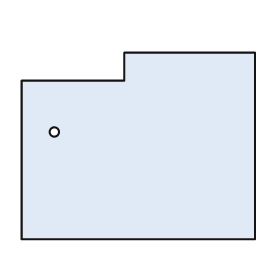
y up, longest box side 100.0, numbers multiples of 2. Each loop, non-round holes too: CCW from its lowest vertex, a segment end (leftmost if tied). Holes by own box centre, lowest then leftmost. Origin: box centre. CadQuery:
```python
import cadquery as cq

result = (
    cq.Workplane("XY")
    .moveTo(-50.0, -40.0)
    .lineTo(50.0, -40.0)
    .lineTo(50.0, 40.0)
    .lineTo(-6.0, 40.0)
    .lineTo(-6.0, 28.0)
    .lineTo(-50.0, 28.0)
    .close()
    .moveTo(-36.0, 6.0)
    .circle(2.0)
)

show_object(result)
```